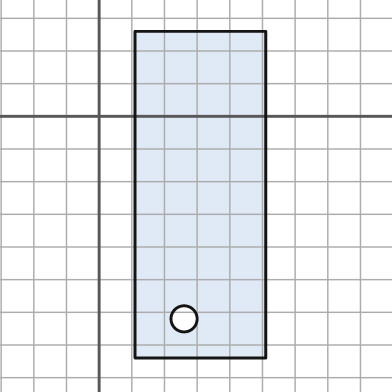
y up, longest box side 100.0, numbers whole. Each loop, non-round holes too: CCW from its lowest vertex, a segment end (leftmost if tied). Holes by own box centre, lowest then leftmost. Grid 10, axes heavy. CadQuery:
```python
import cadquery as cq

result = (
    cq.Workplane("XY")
    .moveTo(11.0, -74.0)
    .lineTo(51.0, -74.0)
    .lineTo(51.0, 26.0)
    .lineTo(11.0, 26.0)
    .close()
    .moveTo(26.0, -62.0)
    .circle(4.0)
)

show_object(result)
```